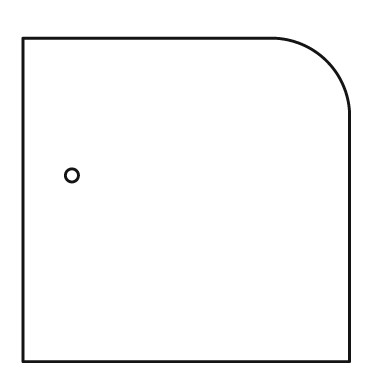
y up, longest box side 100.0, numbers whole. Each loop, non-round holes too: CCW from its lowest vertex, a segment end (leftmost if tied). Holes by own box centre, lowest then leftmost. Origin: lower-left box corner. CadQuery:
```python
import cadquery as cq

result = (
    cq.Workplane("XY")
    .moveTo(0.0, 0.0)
    .lineTo(100.0, 0.0)
    .lineTo(100.0, 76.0)
    .threePointArc((93.0, 92.0), (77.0, 99.0))
    .lineTo(0.0, 99.0)
    .close()
    .moveTo(15.0, 57.0)
    .circle(2.0)
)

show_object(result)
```